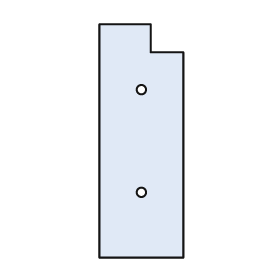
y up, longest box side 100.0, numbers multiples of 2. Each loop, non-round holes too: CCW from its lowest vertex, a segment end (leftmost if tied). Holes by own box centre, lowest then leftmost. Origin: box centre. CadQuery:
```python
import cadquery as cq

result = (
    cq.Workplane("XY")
    .moveTo(-18.0, -50.0)
    .lineTo(18.0, -50.0)
    .lineTo(18.0, 38.0)
    .lineTo(4.0, 38.0)
    .lineTo(4.0, 50.0)
    .lineTo(-18.0, 50.0)
    .close()
    .moveTo(0.0, -22.0)
    .circle(2.0)
    .moveTo(0.0, 22.0)
    .circle(2.0)
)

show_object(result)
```